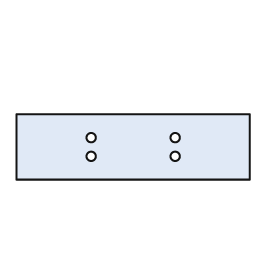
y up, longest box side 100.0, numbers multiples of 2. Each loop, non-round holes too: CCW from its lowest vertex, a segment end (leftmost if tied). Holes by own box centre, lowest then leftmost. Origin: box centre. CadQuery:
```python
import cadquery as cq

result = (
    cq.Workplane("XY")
    .moveTo(-50.0, -14.0)
    .lineTo(50.0, -14.0)
    .lineTo(50.0, 14.0)
    .lineTo(-50.0, 14.0)
    .close()
    .moveTo(-18.0, -4.0)
    .circle(2.0)
    .moveTo(18.0, -4.0)
    .circle(2.0)
    .moveTo(-18.0, 4.0)
    .circle(2.0)
    .moveTo(18.0, 4.0)
    .circle(2.0)
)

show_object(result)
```